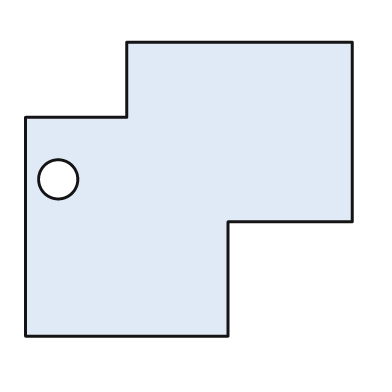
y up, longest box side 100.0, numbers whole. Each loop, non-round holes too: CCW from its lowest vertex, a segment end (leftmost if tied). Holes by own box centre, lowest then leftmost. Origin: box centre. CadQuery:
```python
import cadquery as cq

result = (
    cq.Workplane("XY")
    .moveTo(-50.0, -45.0)
    .lineTo(12.0, -45.0)
    .lineTo(12.0, -10.0)
    .lineTo(50.0, -10.0)
    .lineTo(50.0, 45.0)
    .lineTo(-19.0, 45.0)
    .lineTo(-19.0, 22.0)
    .lineTo(-50.0, 22.0)
    .close()
    .moveTo(-40.0, 3.0)
    .circle(6.0)
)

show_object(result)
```